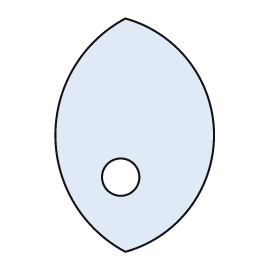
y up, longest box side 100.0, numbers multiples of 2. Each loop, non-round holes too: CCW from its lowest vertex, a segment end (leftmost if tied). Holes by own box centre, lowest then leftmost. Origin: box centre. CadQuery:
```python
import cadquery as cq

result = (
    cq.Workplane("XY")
    .moveTo(-4.0, -50.0)
    .threePointArc((34.0, 0.0), (-4.0, 50.0))
    .threePointArc((-34.0, 0.0), (-4.0, -50.0))
    .close()
    .moveTo(-6.0, -18.0)
    .circle(8.0)
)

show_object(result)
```